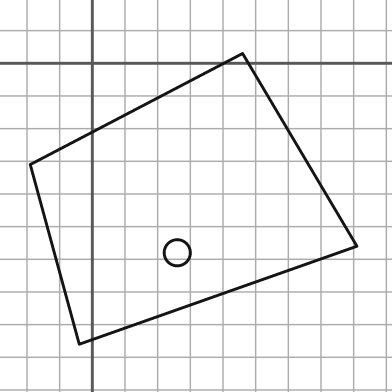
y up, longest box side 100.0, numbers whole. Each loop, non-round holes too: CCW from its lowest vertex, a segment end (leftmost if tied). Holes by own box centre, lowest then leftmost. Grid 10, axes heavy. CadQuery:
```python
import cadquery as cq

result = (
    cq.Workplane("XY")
    .moveTo(-4.0, -86.0)
    .lineTo(81.0, -56.0)
    .lineTo(46.0, 3.0)
    .lineTo(-19.0, -31.0)
    .close()
    .moveTo(26.0, -58.0)
    .circle(4.0)
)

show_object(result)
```